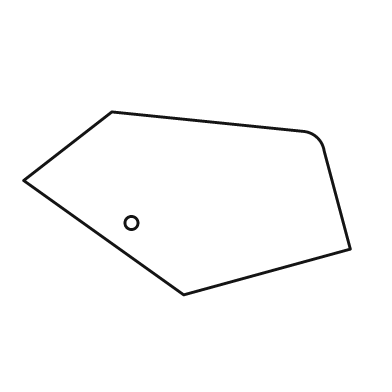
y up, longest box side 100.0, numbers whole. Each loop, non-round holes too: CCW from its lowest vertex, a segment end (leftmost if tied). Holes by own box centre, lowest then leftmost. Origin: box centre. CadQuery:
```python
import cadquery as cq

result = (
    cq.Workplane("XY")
    .moveTo(-1.0, -28.0)
    .lineTo(50.0, -14.0)
    .lineTo(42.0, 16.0)
    .threePointArc((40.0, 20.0), (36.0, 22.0))
    .lineTo(-23.0, 28.0)
    .lineTo(-50.0, 7.0)
    .close()
    .moveTo(-17.0, -6.0)
    .circle(2.0)
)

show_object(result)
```